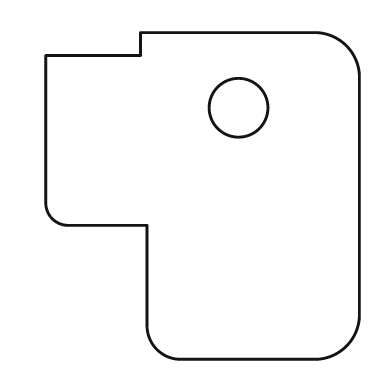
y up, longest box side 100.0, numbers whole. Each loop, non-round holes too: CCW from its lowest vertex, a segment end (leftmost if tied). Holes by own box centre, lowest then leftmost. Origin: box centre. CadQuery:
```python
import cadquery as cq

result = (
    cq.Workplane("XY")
    .moveTo(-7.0, -50.0)
    .lineTo(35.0, -50.0)
    .threePointArc((44.0, -46.0), (48.0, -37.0))
    .lineTo(48.0, 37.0)
    .threePointArc((44.0, 46.0), (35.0, 50.0))
    .lineTo(-19.0, 50.0)
    .lineTo(-19.0, 43.0)
    .lineTo(-48.0, 43.0)
    .lineTo(-48.0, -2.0)
    .threePointArc((-46.0, -7.0), (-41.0, -9.0))
    .lineTo(-17.0, -9.0)
    .lineTo(-17.0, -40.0)
    .threePointArc((-14.0, -47.0), (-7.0, -50.0))
    .close()
    .moveTo(11.0, 27.0)
    .circle(9.0)
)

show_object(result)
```